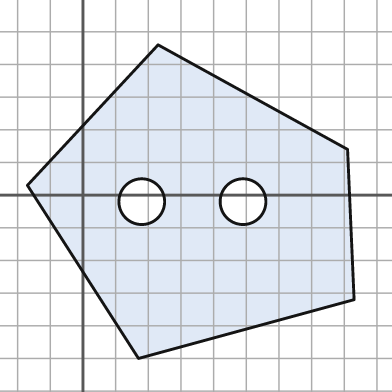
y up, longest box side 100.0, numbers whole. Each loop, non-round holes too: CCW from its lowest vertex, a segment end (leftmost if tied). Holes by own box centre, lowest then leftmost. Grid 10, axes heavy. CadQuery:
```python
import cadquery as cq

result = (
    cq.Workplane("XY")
    .moveTo(17.0, -50.0)
    .lineTo(83.0, -32.0)
    .lineTo(81.0, 14.0)
    .lineTo(23.0, 46.0)
    .lineTo(-17.0, 3.0)
    .close()
    .moveTo(18.0, -2.0)
    .circle(7.0)
    .moveTo(49.0, -2.0)
    .circle(7.0)
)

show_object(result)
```